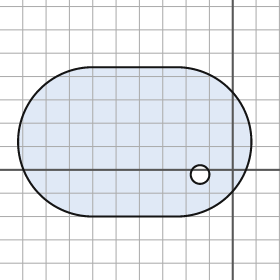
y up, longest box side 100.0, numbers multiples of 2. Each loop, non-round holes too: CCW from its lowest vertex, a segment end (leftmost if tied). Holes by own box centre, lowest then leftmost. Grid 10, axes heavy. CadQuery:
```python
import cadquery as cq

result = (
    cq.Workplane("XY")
    .moveTo(-60.0, -20.0)
    .lineTo(-24.0, -20.0)
    .threePointArc((8.0, 12.0), (-24.0, 44.0))
    .lineTo(-60.0, 44.0)
    .threePointArc((-92.0, 12.0), (-60.0, -20.0))
    .close()
    .moveTo(-14.0, -2.0)
    .circle(4.0)
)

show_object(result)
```